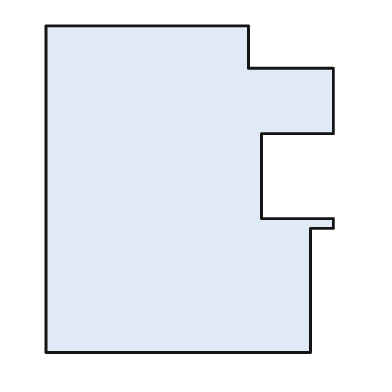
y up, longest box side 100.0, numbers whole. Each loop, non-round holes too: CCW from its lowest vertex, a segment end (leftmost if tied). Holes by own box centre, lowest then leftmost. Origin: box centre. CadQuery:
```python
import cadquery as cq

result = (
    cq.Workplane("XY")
    .moveTo(-44.0, -50.0)
    .lineTo(37.0, -50.0)
    .lineTo(37.0, -12.0)
    .lineTo(44.0, -12.0)
    .lineTo(44.0, -9.0)
    .lineTo(22.0, -9.0)
    .lineTo(22.0, 17.0)
    .lineTo(44.0, 17.0)
    .lineTo(44.0, 37.0)
    .lineTo(18.0, 37.0)
    .lineTo(18.0, 50.0)
    .lineTo(-44.0, 50.0)
    .close()
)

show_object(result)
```